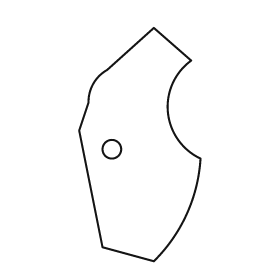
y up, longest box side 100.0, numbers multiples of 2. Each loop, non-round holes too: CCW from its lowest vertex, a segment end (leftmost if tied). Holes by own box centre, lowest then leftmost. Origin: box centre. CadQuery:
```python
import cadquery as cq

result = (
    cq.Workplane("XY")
    .moveTo(6.0, -50.0)
    .threePointArc((20.0, -30.0), (26.0, -6.0))
    .threePointArc((12.0, 14.0), (22.0, 36.0))
    .lineTo(6.0, 50.0)
    .lineTo(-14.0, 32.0)
    .threePointArc((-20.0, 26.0), (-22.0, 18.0))
    .lineTo(-26.0, 6.0)
    .lineTo(-16.0, -44.0)
    .close()
    .moveTo(-12.0, -2.0)
    .circle(4.0)
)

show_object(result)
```